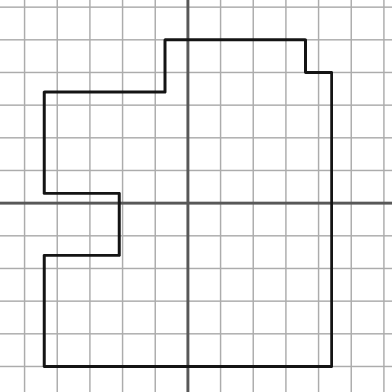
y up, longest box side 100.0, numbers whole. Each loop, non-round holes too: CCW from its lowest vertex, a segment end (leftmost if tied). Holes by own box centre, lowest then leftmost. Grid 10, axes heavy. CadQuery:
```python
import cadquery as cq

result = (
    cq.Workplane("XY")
    .moveTo(-44.0, -50.0)
    .lineTo(44.0, -50.0)
    .lineTo(44.0, 40.0)
    .lineTo(36.0, 40.0)
    .lineTo(36.0, 50.0)
    .lineTo(-7.0, 50.0)
    .lineTo(-7.0, 34.0)
    .lineTo(-44.0, 34.0)
    .lineTo(-44.0, 3.0)
    .lineTo(-21.0, 3.0)
    .lineTo(-21.0, -16.0)
    .lineTo(-44.0, -16.0)
    .close()
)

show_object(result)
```